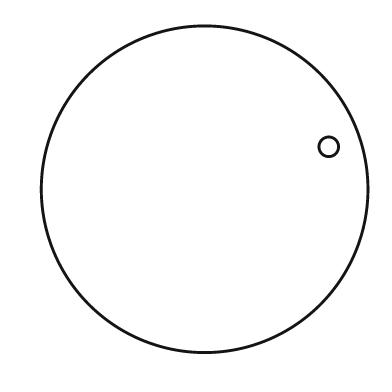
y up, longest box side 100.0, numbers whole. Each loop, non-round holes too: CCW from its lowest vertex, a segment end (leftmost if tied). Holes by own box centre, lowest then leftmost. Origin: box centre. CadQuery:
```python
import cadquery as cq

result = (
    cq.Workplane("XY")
    .moveTo(0.0, 0.0)
    .circle(50.0)
    .moveTo(38.0, 13.0)
    .circle(3.0)
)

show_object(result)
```